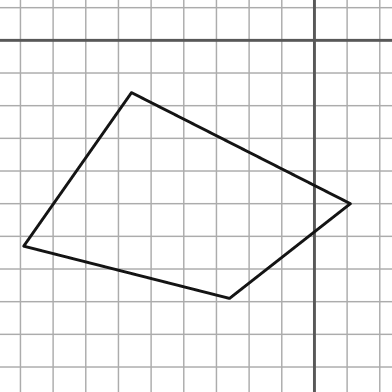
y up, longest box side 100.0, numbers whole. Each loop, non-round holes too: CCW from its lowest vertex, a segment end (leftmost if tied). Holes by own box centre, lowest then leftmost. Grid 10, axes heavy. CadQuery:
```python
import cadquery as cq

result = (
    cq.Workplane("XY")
    .moveTo(-26.0, -79.0)
    .lineTo(11.0, -50.0)
    .lineTo(-56.0, -16.0)
    .lineTo(-89.0, -63.0)
    .close()
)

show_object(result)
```